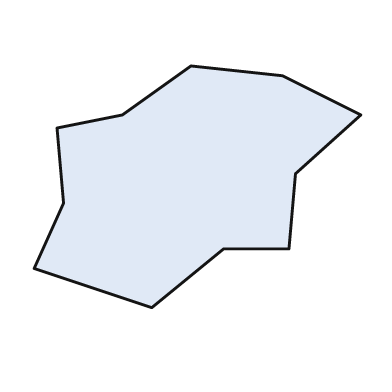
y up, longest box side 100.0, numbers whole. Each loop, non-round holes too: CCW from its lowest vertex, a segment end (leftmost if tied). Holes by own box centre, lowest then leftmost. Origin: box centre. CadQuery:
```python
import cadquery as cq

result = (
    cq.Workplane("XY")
    .moveTo(-14.0, -37.0)
    .lineTo(8.0, -19.0)
    .lineTo(28.0, -19.0)
    .lineTo(30.0, 4.0)
    .lineTo(50.0, 22.0)
    .lineTo(26.0, 34.0)
    .lineTo(-2.0, 37.0)
    .lineTo(-23.0, 22.0)
    .lineTo(-43.0, 18.0)
    .lineTo(-41.0, -5.0)
    .lineTo(-50.0, -25.0)
    .close()
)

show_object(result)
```